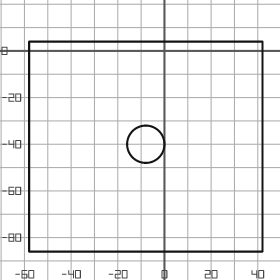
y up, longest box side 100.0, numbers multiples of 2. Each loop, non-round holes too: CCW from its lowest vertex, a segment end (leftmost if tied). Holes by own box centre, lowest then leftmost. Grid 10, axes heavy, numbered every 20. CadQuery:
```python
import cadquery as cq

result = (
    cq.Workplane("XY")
    .moveTo(-58.0, -86.0)
    .lineTo(42.0, -86.0)
    .lineTo(42.0, 4.0)
    .lineTo(-58.0, 4.0)
    .close()
    .moveTo(-8.0, -40.0)
    .circle(8.0)
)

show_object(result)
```